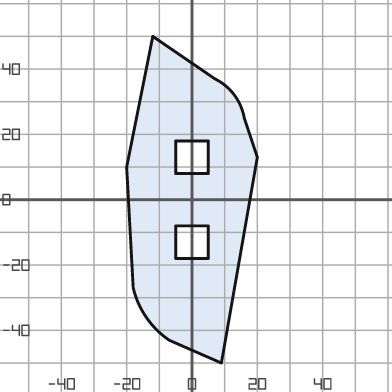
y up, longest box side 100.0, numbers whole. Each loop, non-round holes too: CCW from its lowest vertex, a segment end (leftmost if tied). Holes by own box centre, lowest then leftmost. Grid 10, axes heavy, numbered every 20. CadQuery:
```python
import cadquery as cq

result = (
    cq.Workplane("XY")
    .moveTo(9.0, -50.0)
    .lineTo(20.0, 13.0)
    .lineTo(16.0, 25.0)
    .threePointArc((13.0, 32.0), (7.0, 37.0))
    .lineTo(-12.0, 50.0)
    .lineTo(-20.0, 10.0)
    .lineTo(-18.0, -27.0)
    .threePointArc((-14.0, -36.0), (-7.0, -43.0))
    .close()
    .moveTo(-5.0, -18.0)
    .lineTo(5.0, -18.0)
    .lineTo(5.0, -8.0)
    .lineTo(-5.0, -8.0)
    .close()
    .moveTo(-5.0, 8.0)
    .lineTo(5.0, 8.0)
    .lineTo(5.0, 18.0)
    .lineTo(-5.0, 18.0)
    .close()
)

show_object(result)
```